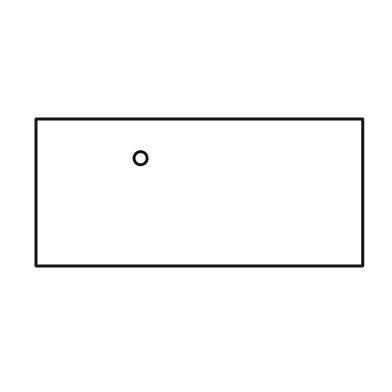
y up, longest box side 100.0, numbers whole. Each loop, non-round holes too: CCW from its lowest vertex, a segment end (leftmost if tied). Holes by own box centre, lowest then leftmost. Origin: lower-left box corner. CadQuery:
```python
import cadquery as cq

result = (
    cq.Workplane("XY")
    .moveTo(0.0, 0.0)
    .lineTo(100.0, 0.0)
    .lineTo(100.0, 45.0)
    .lineTo(0.0, 45.0)
    .close()
    .moveTo(32.0, 33.0)
    .circle(2.0)
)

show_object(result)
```